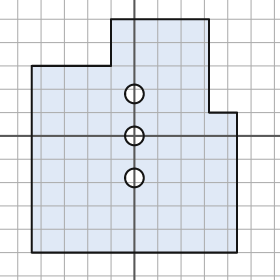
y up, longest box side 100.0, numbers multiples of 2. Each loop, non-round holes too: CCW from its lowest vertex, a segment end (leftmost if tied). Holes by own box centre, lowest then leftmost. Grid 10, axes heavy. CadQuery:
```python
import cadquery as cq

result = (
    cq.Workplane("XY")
    .moveTo(-44.0, -50.0)
    .lineTo(44.0, -50.0)
    .lineTo(44.0, 10.0)
    .lineTo(32.0, 10.0)
    .lineTo(32.0, 50.0)
    .lineTo(-10.0, 50.0)
    .lineTo(-10.0, 30.0)
    .lineTo(-44.0, 30.0)
    .close()
    .moveTo(0.0, -18.0)
    .circle(4.0)
    .moveTo(0.0, 0.0)
    .circle(4.0)
    .moveTo(0.0, 18.0)
    .circle(4.0)
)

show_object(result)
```